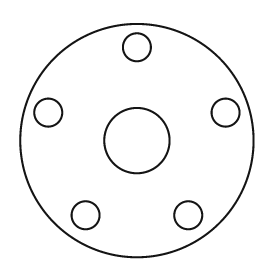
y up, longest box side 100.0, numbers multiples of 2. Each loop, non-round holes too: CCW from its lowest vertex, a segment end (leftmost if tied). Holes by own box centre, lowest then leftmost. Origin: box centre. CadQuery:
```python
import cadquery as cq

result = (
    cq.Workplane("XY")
    .moveTo(0.0, 0.0)
    .circle(50.0)
    .moveTo(-22.0, -32.0)
    .circle(6.0)
    .moveTo(22.0, -32.0)
    .circle(6.0)
    .moveTo(0.0, 0.0)
    .circle(14.0)
    .moveTo(-38.0, 12.0)
    .circle(6.0)
    .moveTo(38.0, 12.0)
    .circle(6.0)
    .moveTo(0.0, 40.0)
    .circle(6.0)
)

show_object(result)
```